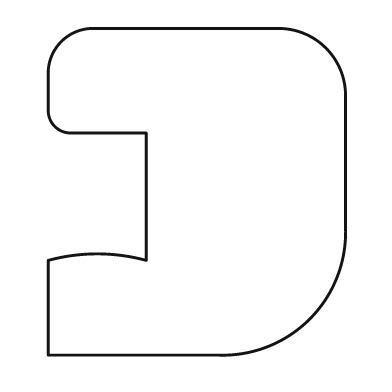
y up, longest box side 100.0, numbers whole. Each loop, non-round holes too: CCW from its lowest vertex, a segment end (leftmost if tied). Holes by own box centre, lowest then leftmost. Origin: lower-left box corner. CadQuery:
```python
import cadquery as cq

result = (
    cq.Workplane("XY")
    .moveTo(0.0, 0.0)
    .lineTo(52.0, 0.0)
    .threePointArc((80.0, 11.0), (91.0, 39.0))
    .lineTo(91.0, 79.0)
    .threePointArc((85.0, 94.0), (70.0, 100.0))
    .lineTo(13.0, 100.0)
    .threePointArc((4.0, 96.0), (0.0, 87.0))
    .lineTo(0.0, 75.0)
    .threePointArc((2.0, 70.0), (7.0, 68.0))
    .lineTo(30.0, 68.0)
    .lineTo(30.0, 29.0)
    .threePointArc((15.0, 31.0), (0.0, 29.0))
    .close()
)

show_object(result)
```